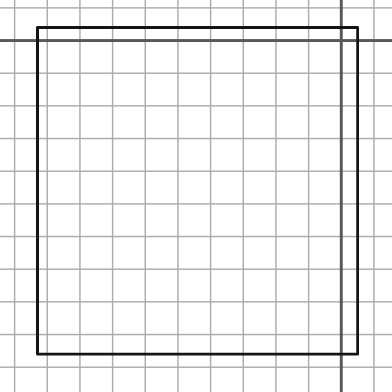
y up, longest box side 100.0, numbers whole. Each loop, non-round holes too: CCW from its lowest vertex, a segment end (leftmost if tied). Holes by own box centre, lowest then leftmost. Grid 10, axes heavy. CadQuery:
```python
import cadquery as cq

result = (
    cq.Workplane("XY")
    .moveTo(-93.0, -96.0)
    .lineTo(5.0, -96.0)
    .lineTo(5.0, 4.0)
    .lineTo(-93.0, 4.0)
    .close()
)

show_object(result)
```